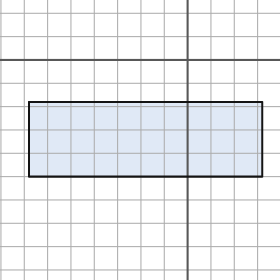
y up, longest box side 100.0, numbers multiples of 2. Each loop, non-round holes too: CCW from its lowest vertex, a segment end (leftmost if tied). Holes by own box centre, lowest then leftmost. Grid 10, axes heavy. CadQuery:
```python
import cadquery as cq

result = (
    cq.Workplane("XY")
    .moveTo(-68.0, -50.0)
    .lineTo(32.0, -50.0)
    .lineTo(32.0, -18.0)
    .lineTo(-68.0, -18.0)
    .close()
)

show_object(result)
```